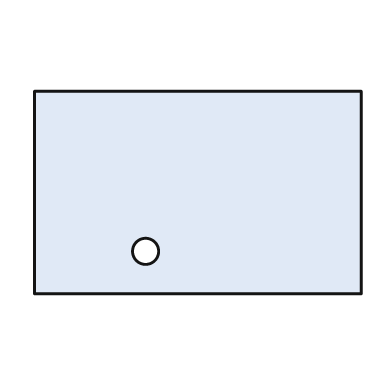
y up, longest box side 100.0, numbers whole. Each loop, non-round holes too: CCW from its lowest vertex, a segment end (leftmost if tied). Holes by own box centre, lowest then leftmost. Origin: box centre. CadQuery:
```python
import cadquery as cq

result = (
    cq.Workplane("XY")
    .moveTo(-50.0, -31.0)
    .lineTo(50.0, -31.0)
    .lineTo(50.0, 31.0)
    .lineTo(-50.0, 31.0)
    .close()
    .moveTo(-16.0, -18.0)
    .circle(4.0)
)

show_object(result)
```